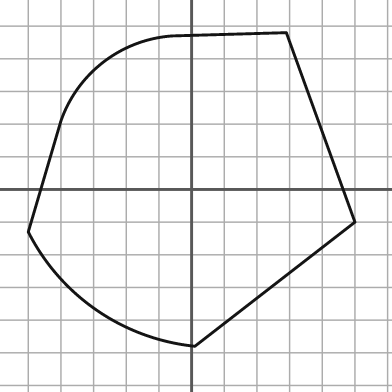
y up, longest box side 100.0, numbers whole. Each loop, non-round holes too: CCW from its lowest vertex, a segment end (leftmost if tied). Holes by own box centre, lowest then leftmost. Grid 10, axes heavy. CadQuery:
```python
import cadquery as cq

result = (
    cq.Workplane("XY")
    .moveTo(1.0, -48.0)
    .lineTo(50.0, -10.0)
    .lineTo(29.0, 48.0)
    .lineTo(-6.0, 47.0)
    .threePointArc((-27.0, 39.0), (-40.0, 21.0))
    .lineTo(-50.0, -13.0)
    .threePointArc((-29.0, -37.0), (1.0, -48.0))
    .close()
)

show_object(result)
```